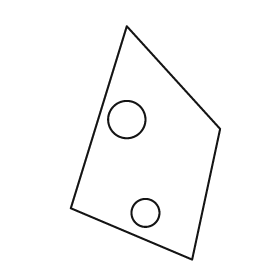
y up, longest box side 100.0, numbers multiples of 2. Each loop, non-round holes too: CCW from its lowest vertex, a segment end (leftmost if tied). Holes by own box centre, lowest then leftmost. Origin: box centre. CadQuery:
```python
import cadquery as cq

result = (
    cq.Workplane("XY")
    .moveTo(20.0, -50.0)
    .lineTo(32.0, 6.0)
    .lineTo(-8.0, 50.0)
    .lineTo(-32.0, -28.0)
    .close()
    .moveTo(0.0, -30.0)
    .circle(6.0)
    .moveTo(-8.0, 10.0)
    .circle(8.0)
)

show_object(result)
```